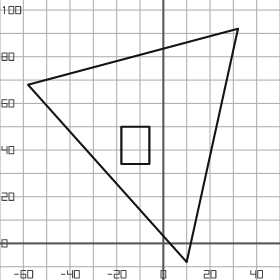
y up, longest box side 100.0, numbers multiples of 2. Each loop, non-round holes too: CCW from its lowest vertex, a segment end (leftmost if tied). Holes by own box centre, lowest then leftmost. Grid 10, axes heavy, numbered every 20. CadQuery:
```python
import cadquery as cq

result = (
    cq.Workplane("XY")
    .moveTo(10.0, -8.0)
    .lineTo(32.0, 92.0)
    .lineTo(-58.0, 68.0)
    .close()
    .moveTo(-18.0, 34.0)
    .lineTo(-6.0, 34.0)
    .lineTo(-6.0, 50.0)
    .lineTo(-18.0, 50.0)
    .close()
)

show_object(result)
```